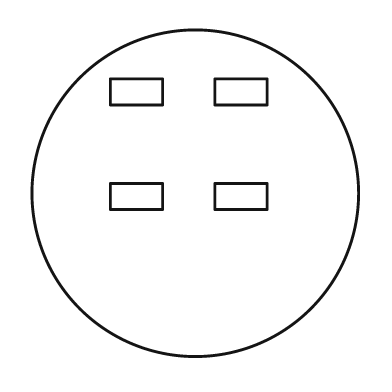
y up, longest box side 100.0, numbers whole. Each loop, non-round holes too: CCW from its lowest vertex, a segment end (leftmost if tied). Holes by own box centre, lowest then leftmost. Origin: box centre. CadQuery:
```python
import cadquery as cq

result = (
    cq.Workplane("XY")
    .moveTo(0.0, 0.0)
    .circle(50.0)
    .moveTo(-26.0, -5.0)
    .lineTo(-10.0, -5.0)
    .lineTo(-10.0, 3.0)
    .lineTo(-26.0, 3.0)
    .close()
    .moveTo(6.0, -5.0)
    .lineTo(22.0, -5.0)
    .lineTo(22.0, 3.0)
    .lineTo(6.0, 3.0)
    .close()
    .moveTo(-26.0, 27.0)
    .lineTo(-10.0, 27.0)
    .lineTo(-10.0, 35.0)
    .lineTo(-26.0, 35.0)
    .close()
    .moveTo(6.0, 27.0)
    .lineTo(22.0, 27.0)
    .lineTo(22.0, 35.0)
    .lineTo(6.0, 35.0)
    .close()
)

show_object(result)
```